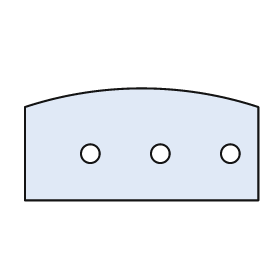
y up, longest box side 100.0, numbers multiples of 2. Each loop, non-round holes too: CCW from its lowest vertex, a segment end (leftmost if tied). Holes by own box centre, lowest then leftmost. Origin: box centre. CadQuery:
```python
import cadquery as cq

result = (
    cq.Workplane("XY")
    .moveTo(-50.0, -24.0)
    .lineTo(50.0, -24.0)
    .lineTo(50.0, 16.0)
    .threePointArc((0.0, 24.0), (-50.0, 16.0))
    .close()
    .moveTo(-22.0, -4.0)
    .circle(4.0)
    .moveTo(8.0, -4.0)
    .circle(4.0)
    .moveTo(38.0, -4.0)
    .circle(4.0)
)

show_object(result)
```